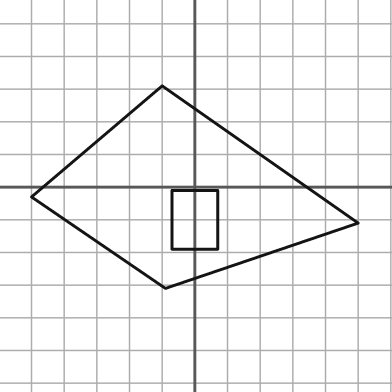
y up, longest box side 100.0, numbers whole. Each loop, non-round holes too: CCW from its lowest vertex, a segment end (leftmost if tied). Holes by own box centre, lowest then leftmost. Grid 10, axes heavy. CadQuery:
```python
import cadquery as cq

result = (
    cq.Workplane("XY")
    .moveTo(-9.0, -31.0)
    .lineTo(50.0, -11.0)
    .lineTo(-10.0, 31.0)
    .lineTo(-50.0, -3.0)
    .close()
    .moveTo(-7.0, -19.0)
    .lineTo(7.0, -19.0)
    .lineTo(7.0, -1.0)
    .lineTo(-7.0, -1.0)
    .close()
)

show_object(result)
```